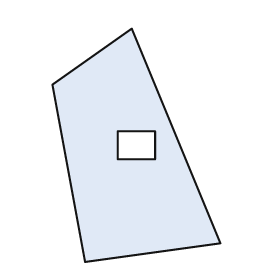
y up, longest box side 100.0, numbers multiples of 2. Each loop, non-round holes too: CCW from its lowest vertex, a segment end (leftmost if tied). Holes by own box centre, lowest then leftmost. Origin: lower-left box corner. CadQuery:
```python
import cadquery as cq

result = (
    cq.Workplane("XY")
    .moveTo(14.0, 0.0)
    .lineTo(72.0, 8.0)
    .lineTo(34.0, 100.0)
    .lineTo(0.0, 76.0)
    .close()
    .moveTo(28.0, 44.0)
    .lineTo(44.0, 44.0)
    .lineTo(44.0, 56.0)
    .lineTo(28.0, 56.0)
    .close()
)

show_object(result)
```